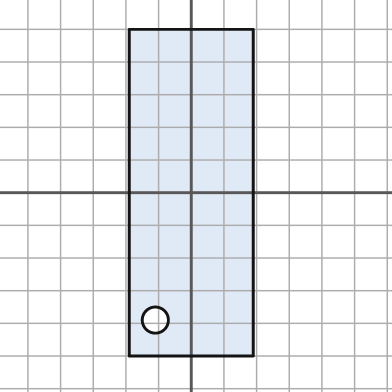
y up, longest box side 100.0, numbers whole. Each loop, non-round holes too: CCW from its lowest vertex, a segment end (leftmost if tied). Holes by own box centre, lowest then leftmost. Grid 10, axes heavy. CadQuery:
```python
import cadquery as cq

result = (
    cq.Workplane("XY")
    .moveTo(-19.0, -50.0)
    .lineTo(19.0, -50.0)
    .lineTo(19.0, 50.0)
    .lineTo(-19.0, 50.0)
    .close()
    .moveTo(-11.0, -39.0)
    .circle(4.0)
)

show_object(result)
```